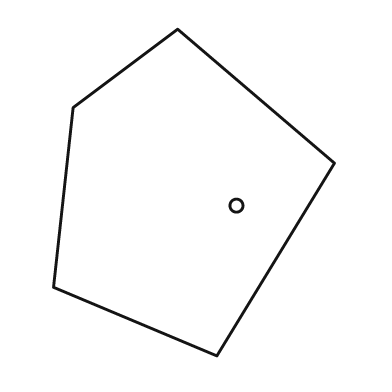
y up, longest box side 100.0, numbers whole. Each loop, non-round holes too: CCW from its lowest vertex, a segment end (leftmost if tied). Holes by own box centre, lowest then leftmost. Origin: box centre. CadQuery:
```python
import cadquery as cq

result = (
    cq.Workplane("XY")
    .moveTo(7.0, -50.0)
    .lineTo(43.0, 9.0)
    .lineTo(-5.0, 50.0)
    .lineTo(-37.0, 26.0)
    .lineTo(-43.0, -29.0)
    .close()
    .moveTo(13.0, -4.0)
    .circle(2.0)
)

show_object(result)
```